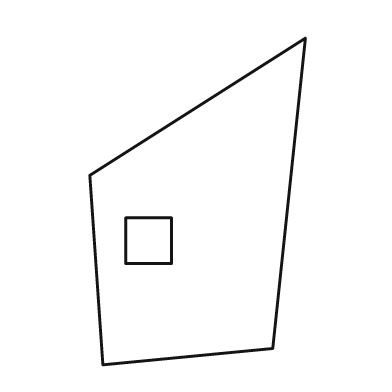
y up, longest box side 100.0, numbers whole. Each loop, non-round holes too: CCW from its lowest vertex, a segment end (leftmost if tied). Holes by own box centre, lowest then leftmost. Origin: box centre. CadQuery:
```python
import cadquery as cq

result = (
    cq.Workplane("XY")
    .moveTo(-29.0, -50.0)
    .lineTo(23.0, -45.0)
    .lineTo(33.0, 50.0)
    .lineTo(-33.0, 8.0)
    .close()
    .moveTo(-22.0, -19.0)
    .lineTo(-8.0, -19.0)
    .lineTo(-8.0, -5.0)
    .lineTo(-22.0, -5.0)
    .close()
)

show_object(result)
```